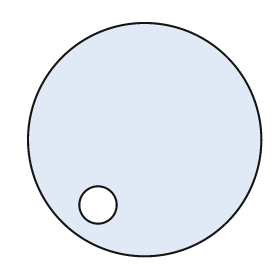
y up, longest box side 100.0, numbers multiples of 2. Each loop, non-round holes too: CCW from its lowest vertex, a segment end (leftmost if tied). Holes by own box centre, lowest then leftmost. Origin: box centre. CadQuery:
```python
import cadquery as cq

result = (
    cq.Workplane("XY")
    .moveTo(0.0, 0.0)
    .circle(50.0)
    .moveTo(-20.0, -28.0)
    .circle(8.0)
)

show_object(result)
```